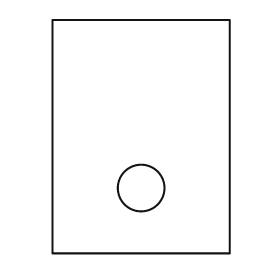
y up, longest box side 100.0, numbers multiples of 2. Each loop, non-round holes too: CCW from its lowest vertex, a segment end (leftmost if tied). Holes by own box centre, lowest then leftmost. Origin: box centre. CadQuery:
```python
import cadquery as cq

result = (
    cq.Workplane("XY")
    .moveTo(-38.0, -50.0)
    .lineTo(38.0, -50.0)
    .lineTo(38.0, 50.0)
    .lineTo(-38.0, 50.0)
    .close()
    .moveTo(0.0, -22.0)
    .circle(10.0)
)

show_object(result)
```